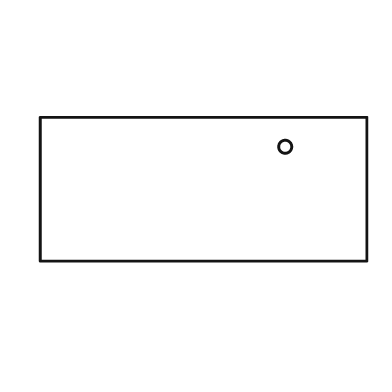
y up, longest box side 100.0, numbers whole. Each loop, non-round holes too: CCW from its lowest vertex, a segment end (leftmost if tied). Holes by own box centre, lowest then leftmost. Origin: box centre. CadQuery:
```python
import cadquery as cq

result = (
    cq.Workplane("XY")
    .moveTo(-50.0, -22.0)
    .lineTo(50.0, -22.0)
    .lineTo(50.0, 22.0)
    .lineTo(-50.0, 22.0)
    .close()
    .moveTo(25.0, 13.0)
    .circle(2.0)
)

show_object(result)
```